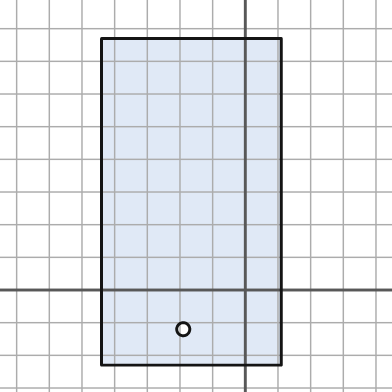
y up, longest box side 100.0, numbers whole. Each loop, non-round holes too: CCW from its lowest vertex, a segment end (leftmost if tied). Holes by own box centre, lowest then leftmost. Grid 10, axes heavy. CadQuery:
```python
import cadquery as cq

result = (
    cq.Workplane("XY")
    .moveTo(-44.0, -23.0)
    .lineTo(11.0, -23.0)
    .lineTo(11.0, 77.0)
    .lineTo(-44.0, 77.0)
    .close()
    .moveTo(-19.0, -12.0)
    .circle(2.0)
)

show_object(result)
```